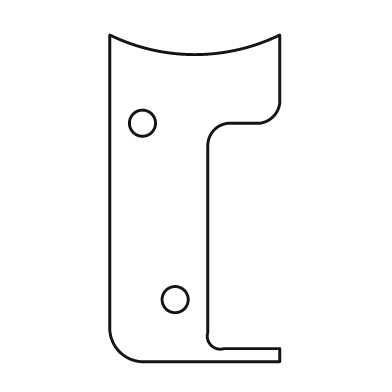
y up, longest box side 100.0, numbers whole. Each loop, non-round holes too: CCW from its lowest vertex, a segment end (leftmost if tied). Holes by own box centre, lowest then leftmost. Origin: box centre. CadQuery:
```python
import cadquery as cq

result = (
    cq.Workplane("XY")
    .moveTo(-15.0, -50.0)
    .lineTo(26.0, -50.0)
    .lineTo(26.0, -46.0)
    .lineTo(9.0, -46.0)
    .threePointArc((5.0, -45.0), (4.0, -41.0))
    .lineTo(4.0, 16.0)
    .threePointArc((6.0, 21.0), (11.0, 23.0))
    .lineTo(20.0, 23.0)
    .threePointArc((24.0, 25.0), (26.0, 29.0))
    .lineTo(26.0, 50.0)
    .threePointArc((0.0, 44.0), (-26.0, 50.0))
    .lineTo(-26.0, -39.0)
    .threePointArc((-23.0, -47.0), (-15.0, -50.0))
    .close()
    .moveTo(-6.0, -31.0)
    .circle(4.0)
    .moveTo(-16.0, 23.0)
    .circle(4.0)
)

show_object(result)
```